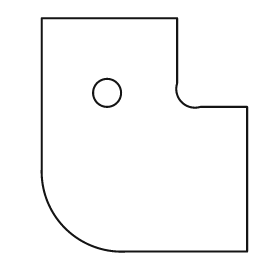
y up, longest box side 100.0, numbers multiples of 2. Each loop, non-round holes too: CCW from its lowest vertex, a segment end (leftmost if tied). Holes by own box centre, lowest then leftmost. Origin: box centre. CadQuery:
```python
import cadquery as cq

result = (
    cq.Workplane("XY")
    .moveTo(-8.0, -50.0)
    .lineTo(44.0, -50.0)
    .lineTo(44.0, 12.0)
    .lineTo(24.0, 12.0)
    .threePointArc((16.0, 14.0), (14.0, 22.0))
    .lineTo(14.0, 50.0)
    .lineTo(-44.0, 50.0)
    .lineTo(-44.0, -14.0)
    .threePointArc((-34.0, -40.0), (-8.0, -50.0))
    .close()
    .moveTo(-16.0, 18.0)
    .circle(6.0)
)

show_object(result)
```